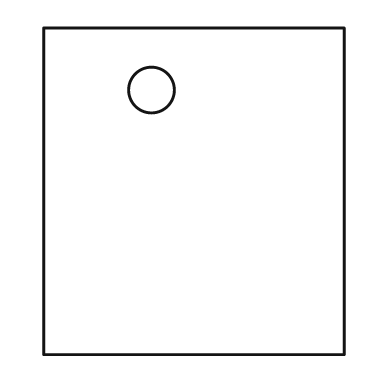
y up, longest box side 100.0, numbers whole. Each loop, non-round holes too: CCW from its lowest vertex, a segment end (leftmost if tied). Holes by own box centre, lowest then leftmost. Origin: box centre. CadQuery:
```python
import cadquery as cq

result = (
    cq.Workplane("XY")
    .moveTo(-46.0, -50.0)
    .lineTo(46.0, -50.0)
    .lineTo(46.0, 50.0)
    .lineTo(-46.0, 50.0)
    .close()
    .moveTo(-13.0, 31.0)
    .circle(7.0)
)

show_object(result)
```